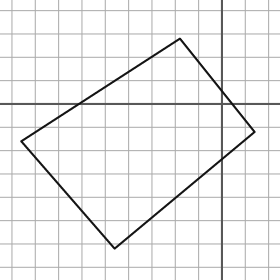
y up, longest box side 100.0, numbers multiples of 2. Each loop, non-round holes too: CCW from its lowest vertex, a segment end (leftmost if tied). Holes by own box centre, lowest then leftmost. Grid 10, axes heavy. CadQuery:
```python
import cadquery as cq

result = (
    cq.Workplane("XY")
    .moveTo(-46.0, -62.0)
    .lineTo(14.0, -12.0)
    .lineTo(-18.0, 28.0)
    .lineTo(-86.0, -16.0)
    .close()
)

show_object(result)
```